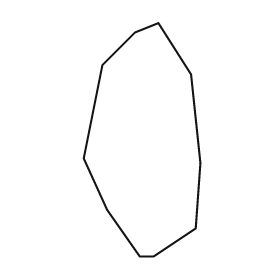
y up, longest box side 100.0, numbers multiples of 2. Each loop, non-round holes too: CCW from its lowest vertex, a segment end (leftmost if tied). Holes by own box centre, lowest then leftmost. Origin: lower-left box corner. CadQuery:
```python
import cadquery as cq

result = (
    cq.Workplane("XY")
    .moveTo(24.0, 0.0)
    .lineTo(30.0, 0.0)
    .lineTo(48.0, 12.0)
    .lineTo(50.0, 40.0)
    .lineTo(46.0, 78.0)
    .lineTo(32.0, 100.0)
    .lineTo(22.0, 96.0)
    .lineTo(8.0, 82.0)
    .lineTo(0.0, 42.0)
    .lineTo(10.0, 20.0)
    .close()
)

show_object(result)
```